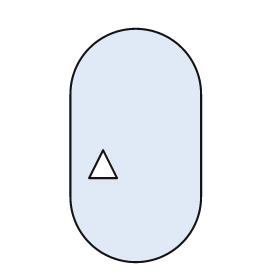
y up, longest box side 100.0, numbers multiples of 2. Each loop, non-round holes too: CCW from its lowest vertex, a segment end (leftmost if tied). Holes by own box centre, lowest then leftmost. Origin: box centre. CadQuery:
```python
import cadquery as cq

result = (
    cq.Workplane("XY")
    .moveTo(-28.0, -22.0)
    .threePointArc((0.0, -50.0), (28.0, -22.0))
    .lineTo(28.0, 22.0)
    .threePointArc((0.0, 50.0), (-28.0, 22.0))
    .close()
    .moveTo(-20.0, -14.0)
    .lineTo(-8.0, -14.0)
    .lineTo(-14.0, -2.0)
    .close()
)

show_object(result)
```